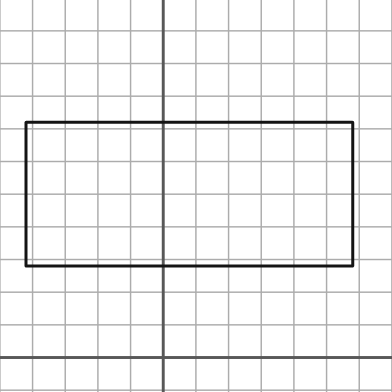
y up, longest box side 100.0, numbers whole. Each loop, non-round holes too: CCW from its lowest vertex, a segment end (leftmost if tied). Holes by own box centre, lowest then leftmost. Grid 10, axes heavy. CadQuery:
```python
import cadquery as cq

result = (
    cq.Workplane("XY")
    .moveTo(-42.0, 28.0)
    .lineTo(58.0, 28.0)
    .lineTo(58.0, 72.0)
    .lineTo(-42.0, 72.0)
    .close()
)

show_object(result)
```